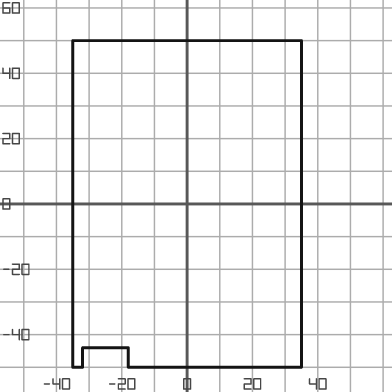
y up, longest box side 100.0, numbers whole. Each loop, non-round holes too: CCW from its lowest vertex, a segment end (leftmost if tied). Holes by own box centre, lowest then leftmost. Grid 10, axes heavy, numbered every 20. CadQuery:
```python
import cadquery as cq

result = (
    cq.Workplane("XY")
    .moveTo(-35.0, -50.0)
    .lineTo(-32.0, -50.0)
    .lineTo(-32.0, -44.0)
    .lineTo(-18.0, -44.0)
    .lineTo(-18.0, -50.0)
    .lineTo(35.0, -50.0)
    .lineTo(35.0, 50.0)
    .lineTo(-35.0, 50.0)
    .close()
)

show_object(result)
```